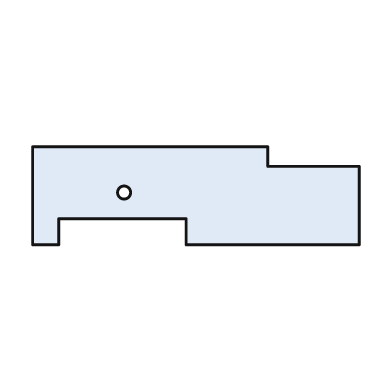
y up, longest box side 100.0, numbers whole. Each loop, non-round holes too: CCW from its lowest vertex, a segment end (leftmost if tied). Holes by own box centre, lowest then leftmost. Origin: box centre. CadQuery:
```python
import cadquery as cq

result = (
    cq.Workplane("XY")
    .moveTo(-50.0, -15.0)
    .lineTo(-42.0, -15.0)
    .lineTo(-42.0, -7.0)
    .lineTo(-3.0, -7.0)
    .lineTo(-3.0, -15.0)
    .lineTo(50.0, -15.0)
    .lineTo(50.0, 9.0)
    .lineTo(22.0, 9.0)
    .lineTo(22.0, 15.0)
    .lineTo(-50.0, 15.0)
    .close()
    .moveTo(-22.0, 1.0)
    .circle(2.0)
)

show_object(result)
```